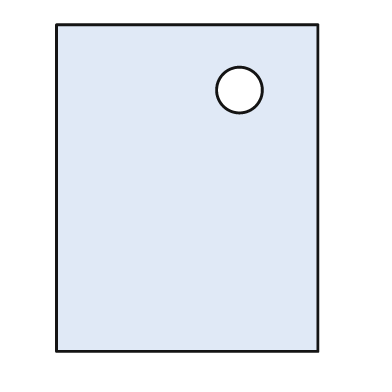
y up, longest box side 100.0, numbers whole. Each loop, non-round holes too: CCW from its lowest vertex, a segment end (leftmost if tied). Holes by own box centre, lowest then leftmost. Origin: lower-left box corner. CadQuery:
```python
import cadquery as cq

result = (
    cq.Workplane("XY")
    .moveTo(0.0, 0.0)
    .lineTo(80.0, 0.0)
    .lineTo(80.0, 100.0)
    .lineTo(0.0, 100.0)
    .close()
    .moveTo(56.0, 80.0)
    .circle(7.0)
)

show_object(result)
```